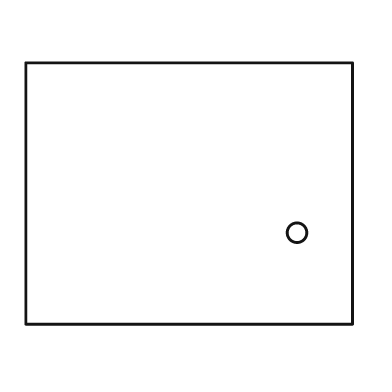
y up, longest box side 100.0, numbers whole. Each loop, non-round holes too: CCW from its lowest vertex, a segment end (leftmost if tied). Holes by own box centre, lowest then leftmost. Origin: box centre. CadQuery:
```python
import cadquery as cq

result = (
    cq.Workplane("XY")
    .moveTo(-50.0, -40.0)
    .lineTo(50.0, -40.0)
    .lineTo(50.0, 40.0)
    .lineTo(-50.0, 40.0)
    .close()
    .moveTo(33.0, -12.0)
    .circle(3.0)
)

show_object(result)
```